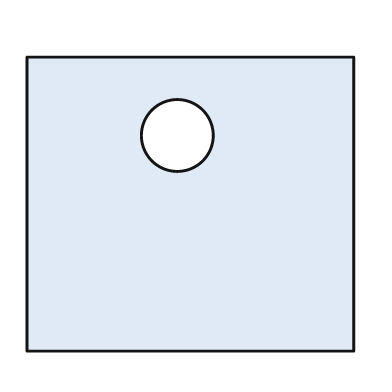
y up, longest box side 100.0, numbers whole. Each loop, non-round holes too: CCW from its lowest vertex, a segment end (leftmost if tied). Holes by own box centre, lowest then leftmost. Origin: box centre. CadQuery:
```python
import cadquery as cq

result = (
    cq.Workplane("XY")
    .moveTo(-50.0, -45.0)
    .lineTo(50.0, -45.0)
    .lineTo(50.0, 45.0)
    .lineTo(-50.0, 45.0)
    .close()
    .moveTo(-4.0, 21.0)
    .circle(11.0)
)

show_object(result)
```